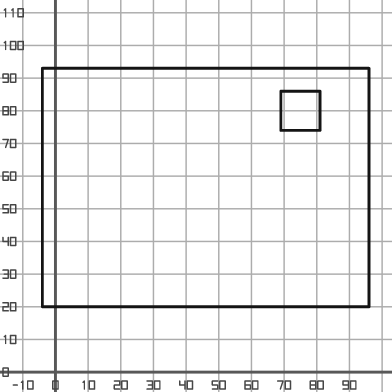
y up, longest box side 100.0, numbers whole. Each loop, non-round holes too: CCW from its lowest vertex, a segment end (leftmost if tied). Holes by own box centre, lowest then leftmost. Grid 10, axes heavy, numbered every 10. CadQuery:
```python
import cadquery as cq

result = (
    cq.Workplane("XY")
    .moveTo(-4.0, 20.0)
    .lineTo(96.0, 20.0)
    .lineTo(96.0, 93.0)
    .lineTo(-4.0, 93.0)
    .close()
    .moveTo(69.0, 74.0)
    .lineTo(81.0, 74.0)
    .lineTo(81.0, 86.0)
    .lineTo(69.0, 86.0)
    .close()
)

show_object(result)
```